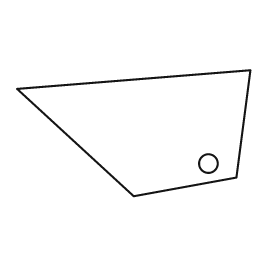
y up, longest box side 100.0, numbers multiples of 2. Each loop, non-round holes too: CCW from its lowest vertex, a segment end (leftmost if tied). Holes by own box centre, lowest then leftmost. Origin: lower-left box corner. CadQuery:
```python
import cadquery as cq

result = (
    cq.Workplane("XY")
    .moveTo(50.0, 0.0)
    .lineTo(94.0, 8.0)
    .lineTo(100.0, 54.0)
    .lineTo(0.0, 46.0)
    .close()
    .moveTo(82.0, 14.0)
    .circle(4.0)
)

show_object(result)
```